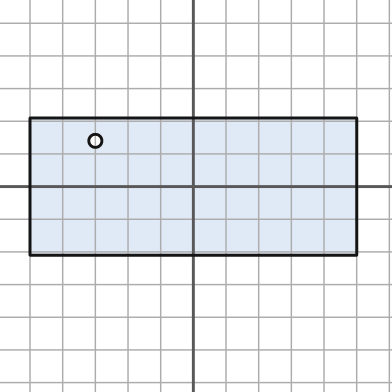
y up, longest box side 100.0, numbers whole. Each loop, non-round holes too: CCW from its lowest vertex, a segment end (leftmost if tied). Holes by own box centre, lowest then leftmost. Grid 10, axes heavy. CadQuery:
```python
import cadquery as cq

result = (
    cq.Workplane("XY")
    .moveTo(-50.0, -21.0)
    .lineTo(50.0, -21.0)
    .lineTo(50.0, 21.0)
    .lineTo(-50.0, 21.0)
    .close()
    .moveTo(-30.0, 14.0)
    .circle(2.0)
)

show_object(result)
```